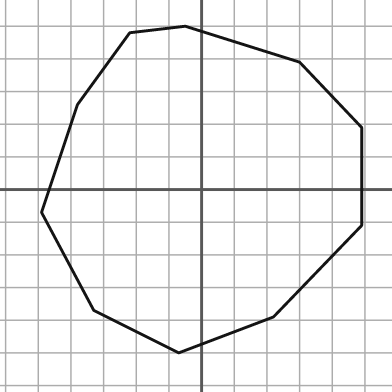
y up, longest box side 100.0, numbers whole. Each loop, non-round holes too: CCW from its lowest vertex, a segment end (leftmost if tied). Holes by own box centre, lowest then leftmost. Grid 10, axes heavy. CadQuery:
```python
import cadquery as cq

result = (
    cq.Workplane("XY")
    .moveTo(-7.0, -50.0)
    .lineTo(22.0, -39.0)
    .lineTo(49.0, -11.0)
    .lineTo(49.0, 19.0)
    .lineTo(30.0, 39.0)
    .lineTo(-5.0, 50.0)
    .lineTo(-22.0, 48.0)
    .lineTo(-38.0, 26.0)
    .lineTo(-49.0, -7.0)
    .lineTo(-33.0, -37.0)
    .close()
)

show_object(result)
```